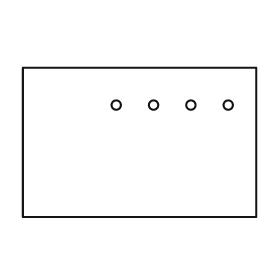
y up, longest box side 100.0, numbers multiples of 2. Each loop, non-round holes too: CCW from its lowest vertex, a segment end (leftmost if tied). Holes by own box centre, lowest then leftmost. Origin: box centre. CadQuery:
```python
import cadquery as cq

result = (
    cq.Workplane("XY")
    .moveTo(-50.0, -32.0)
    .lineTo(50.0, -32.0)
    .lineTo(50.0, 32.0)
    .lineTo(-50.0, 32.0)
    .close()
    .moveTo(-10.0, 16.0)
    .circle(2.0)
    .moveTo(6.0, 16.0)
    .circle(2.0)
    .moveTo(22.0, 16.0)
    .circle(2.0)
    .moveTo(38.0, 16.0)
    .circle(2.0)
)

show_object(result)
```